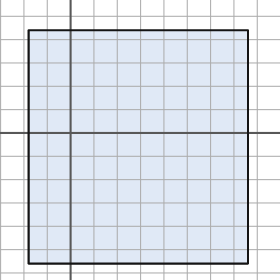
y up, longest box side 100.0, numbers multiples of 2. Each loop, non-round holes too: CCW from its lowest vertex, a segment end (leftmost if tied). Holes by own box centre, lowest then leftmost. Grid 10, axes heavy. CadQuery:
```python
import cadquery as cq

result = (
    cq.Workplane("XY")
    .moveTo(-18.0, -56.0)
    .lineTo(76.0, -56.0)
    .lineTo(76.0, 44.0)
    .lineTo(-18.0, 44.0)
    .close()
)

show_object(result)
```